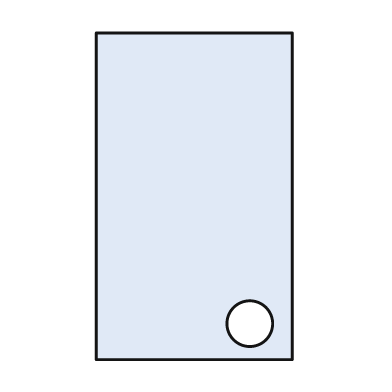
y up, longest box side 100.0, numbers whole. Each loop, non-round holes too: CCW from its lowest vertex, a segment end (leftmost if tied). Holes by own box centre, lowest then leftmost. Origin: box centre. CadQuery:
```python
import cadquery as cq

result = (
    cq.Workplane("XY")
    .moveTo(-30.0, -50.0)
    .lineTo(30.0, -50.0)
    .lineTo(30.0, 50.0)
    .lineTo(-30.0, 50.0)
    .close()
    .moveTo(17.0, -39.0)
    .circle(7.0)
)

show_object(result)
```